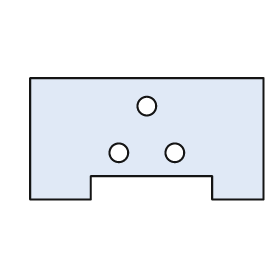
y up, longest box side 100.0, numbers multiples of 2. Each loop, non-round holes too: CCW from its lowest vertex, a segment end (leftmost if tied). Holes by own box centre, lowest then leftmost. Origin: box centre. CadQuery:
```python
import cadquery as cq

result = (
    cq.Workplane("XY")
    .moveTo(-50.0, -26.0)
    .lineTo(-24.0, -26.0)
    .lineTo(-24.0, -16.0)
    .lineTo(28.0, -16.0)
    .lineTo(28.0, -26.0)
    .lineTo(50.0, -26.0)
    .lineTo(50.0, 26.0)
    .lineTo(-50.0, 26.0)
    .close()
    .moveTo(-12.0, -6.0)
    .circle(4.0)
    .moveTo(12.0, -6.0)
    .circle(4.0)
    .moveTo(0.0, 14.0)
    .circle(4.0)
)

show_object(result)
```